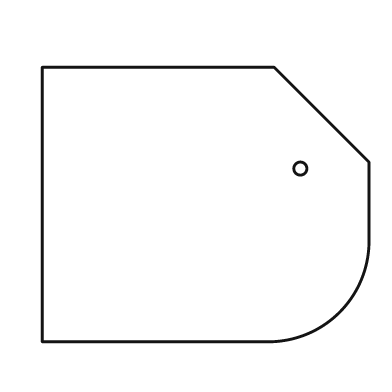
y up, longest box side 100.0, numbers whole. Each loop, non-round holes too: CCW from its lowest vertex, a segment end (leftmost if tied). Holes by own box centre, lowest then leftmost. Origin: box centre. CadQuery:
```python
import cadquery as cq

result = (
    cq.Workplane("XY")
    .moveTo(-50.0, -42.0)
    .lineTo(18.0, -42.0)
    .threePointArc((41.0, -33.0), (50.0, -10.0))
    .lineTo(50.0, 13.0)
    .lineTo(21.0, 42.0)
    .lineTo(-50.0, 42.0)
    .close()
    .moveTo(29.0, 11.0)
    .circle(2.0)
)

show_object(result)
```